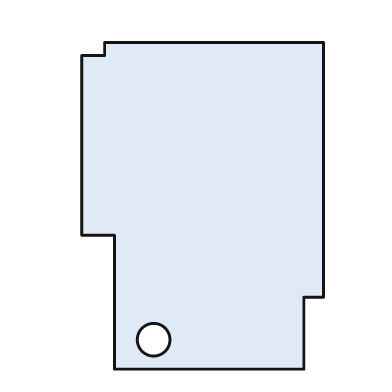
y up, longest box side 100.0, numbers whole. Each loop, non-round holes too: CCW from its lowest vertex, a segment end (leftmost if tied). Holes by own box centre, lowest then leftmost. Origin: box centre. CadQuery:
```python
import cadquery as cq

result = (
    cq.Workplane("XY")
    .moveTo(-27.0, -50.0)
    .lineTo(31.0, -50.0)
    .lineTo(31.0, -28.0)
    .lineTo(37.0, -28.0)
    .lineTo(37.0, 50.0)
    .lineTo(-30.0, 50.0)
    .lineTo(-30.0, 46.0)
    .lineTo(-37.0, 46.0)
    .lineTo(-37.0, -9.0)
    .lineTo(-27.0, -9.0)
    .close()
    .moveTo(-15.0, -41.0)
    .circle(5.0)
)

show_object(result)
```